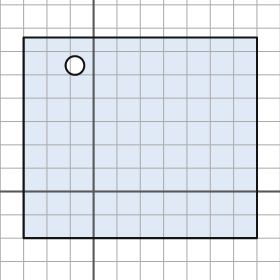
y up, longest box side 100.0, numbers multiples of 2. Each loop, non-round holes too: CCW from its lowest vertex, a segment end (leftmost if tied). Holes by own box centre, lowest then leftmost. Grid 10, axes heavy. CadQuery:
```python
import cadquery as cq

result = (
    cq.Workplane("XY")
    .moveTo(-30.0, -20.0)
    .lineTo(70.0, -20.0)
    .lineTo(70.0, 66.0)
    .lineTo(-30.0, 66.0)
    .close()
    .moveTo(-8.0, 54.0)
    .circle(4.0)
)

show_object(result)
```